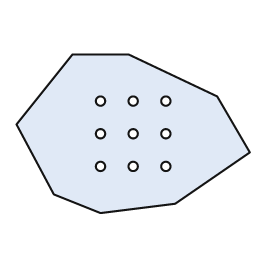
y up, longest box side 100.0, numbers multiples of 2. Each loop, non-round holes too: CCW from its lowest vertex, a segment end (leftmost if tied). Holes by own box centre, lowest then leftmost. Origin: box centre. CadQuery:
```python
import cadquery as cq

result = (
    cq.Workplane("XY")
    .moveTo(-14.0, -34.0)
    .lineTo(18.0, -30.0)
    .lineTo(50.0, -8.0)
    .lineTo(36.0, 16.0)
    .lineTo(-2.0, 34.0)
    .lineTo(-26.0, 34.0)
    .lineTo(-50.0, 4.0)
    .lineTo(-34.0, -26.0)
    .close()
    .moveTo(-14.0, -14.0)
    .circle(2.0)
    .moveTo(0.0, -14.0)
    .circle(2.0)
    .moveTo(14.0, -14.0)
    .circle(2.0)
    .moveTo(-14.0, 0.0)
    .circle(2.0)
    .moveTo(0.0, 0.0)
    .circle(2.0)
    .moveTo(14.0, 0.0)
    .circle(2.0)
    .moveTo(-14.0, 14.0)
    .circle(2.0)
    .moveTo(0.0, 14.0)
    .circle(2.0)
    .moveTo(14.0, 14.0)
    .circle(2.0)
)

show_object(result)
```